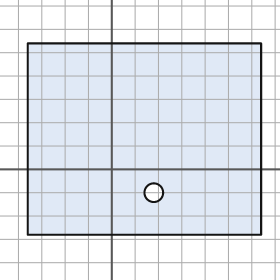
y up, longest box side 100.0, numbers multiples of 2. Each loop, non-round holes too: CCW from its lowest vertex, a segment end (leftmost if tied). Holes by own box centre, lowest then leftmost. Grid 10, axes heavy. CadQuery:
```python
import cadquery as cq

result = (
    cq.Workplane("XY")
    .moveTo(-36.0, -28.0)
    .lineTo(64.0, -28.0)
    .lineTo(64.0, 54.0)
    .lineTo(-36.0, 54.0)
    .close()
    .moveTo(18.0, -10.0)
    .circle(4.0)
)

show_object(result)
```